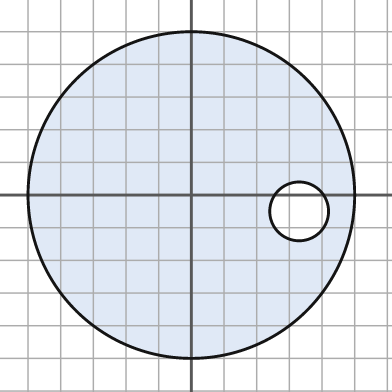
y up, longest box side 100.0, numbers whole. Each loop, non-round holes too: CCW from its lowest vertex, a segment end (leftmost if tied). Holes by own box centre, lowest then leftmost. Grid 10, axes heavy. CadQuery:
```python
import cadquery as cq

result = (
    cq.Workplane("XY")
    .moveTo(0.0, 0.0)
    .circle(50.0)
    .moveTo(33.0, -5.0)
    .circle(9.0)
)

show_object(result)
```